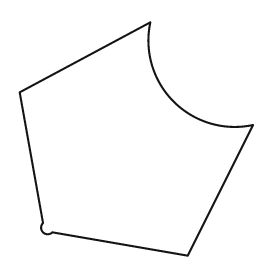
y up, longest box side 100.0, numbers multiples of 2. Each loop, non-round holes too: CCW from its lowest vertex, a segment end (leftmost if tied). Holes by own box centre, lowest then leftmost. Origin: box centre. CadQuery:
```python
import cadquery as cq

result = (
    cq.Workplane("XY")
    .moveTo(22.0, -50.0)
    .lineTo(50.0, 6.0)
    .threePointArc((16.0, 16.0), (6.0, 50.0))
    .lineTo(-50.0, 20.0)
    .lineTo(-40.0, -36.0)
    .threePointArc((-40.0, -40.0), (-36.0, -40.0))
    .close()
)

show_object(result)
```